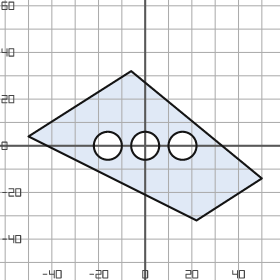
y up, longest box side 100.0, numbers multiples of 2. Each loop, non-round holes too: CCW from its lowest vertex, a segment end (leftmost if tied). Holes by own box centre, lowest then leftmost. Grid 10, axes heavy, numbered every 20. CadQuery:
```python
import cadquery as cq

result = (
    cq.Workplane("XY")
    .moveTo(22.0, -32.0)
    .lineTo(50.0, -14.0)
    .lineTo(-6.0, 32.0)
    .lineTo(-50.0, 4.0)
    .close()
    .moveTo(-16.0, 0.0)
    .circle(6.0)
    .moveTo(0.0, 0.0)
    .circle(6.0)
    .moveTo(16.0, 0.0)
    .circle(6.0)
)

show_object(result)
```